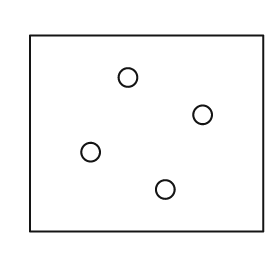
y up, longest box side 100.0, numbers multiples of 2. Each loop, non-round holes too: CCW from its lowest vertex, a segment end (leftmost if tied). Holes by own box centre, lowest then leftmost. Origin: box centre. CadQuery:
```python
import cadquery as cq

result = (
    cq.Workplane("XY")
    .moveTo(-50.0, -42.0)
    .lineTo(50.0, -42.0)
    .lineTo(50.0, 42.0)
    .lineTo(-50.0, 42.0)
    .close()
    .moveTo(8.0, -24.0)
    .circle(4.0)
    .moveTo(-24.0, -8.0)
    .circle(4.0)
    .moveTo(24.0, 8.0)
    .circle(4.0)
    .moveTo(-8.0, 24.0)
    .circle(4.0)
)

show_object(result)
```